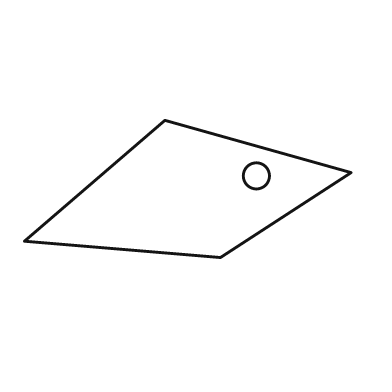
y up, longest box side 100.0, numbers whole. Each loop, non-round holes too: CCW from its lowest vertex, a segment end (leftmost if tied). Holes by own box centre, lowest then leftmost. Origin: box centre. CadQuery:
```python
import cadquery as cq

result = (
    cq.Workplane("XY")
    .moveTo(10.0, -21.0)
    .lineTo(50.0, 5.0)
    .lineTo(-7.0, 21.0)
    .lineTo(-50.0, -16.0)
    .close()
    .moveTo(21.0, 4.0)
    .circle(4.0)
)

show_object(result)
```